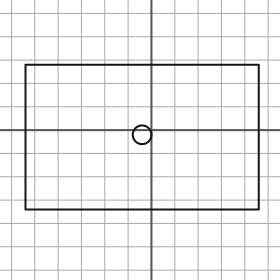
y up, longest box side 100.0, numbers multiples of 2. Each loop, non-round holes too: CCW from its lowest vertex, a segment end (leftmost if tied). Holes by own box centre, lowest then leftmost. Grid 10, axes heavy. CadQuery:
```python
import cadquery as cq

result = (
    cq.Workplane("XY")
    .moveTo(-54.0, -34.0)
    .lineTo(46.0, -34.0)
    .lineTo(46.0, 28.0)
    .lineTo(-54.0, 28.0)
    .close()
    .moveTo(-4.0, -2.0)
    .circle(4.0)
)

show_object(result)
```